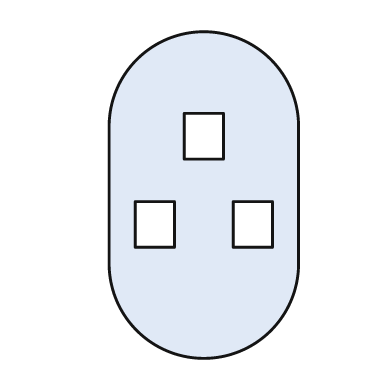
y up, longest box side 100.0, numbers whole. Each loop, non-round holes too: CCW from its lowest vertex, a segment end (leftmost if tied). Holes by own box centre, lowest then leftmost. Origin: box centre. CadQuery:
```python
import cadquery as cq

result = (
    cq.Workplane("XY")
    .moveTo(-29.0, -21.0)
    .threePointArc((0.0, -50.0), (29.0, -21.0))
    .lineTo(29.0, 21.0)
    .threePointArc((0.0, 50.0), (-29.0, 21.0))
    .close()
    .moveTo(-21.0, -16.0)
    .lineTo(-9.0, -16.0)
    .lineTo(-9.0, -2.0)
    .lineTo(-21.0, -2.0)
    .close()
    .moveTo(9.0, -16.0)
    .lineTo(21.0, -16.0)
    .lineTo(21.0, -2.0)
    .lineTo(9.0, -2.0)
    .close()
    .moveTo(-6.0, 11.0)
    .lineTo(6.0, 11.0)
    .lineTo(6.0, 25.0)
    .lineTo(-6.0, 25.0)
    .close()
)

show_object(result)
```